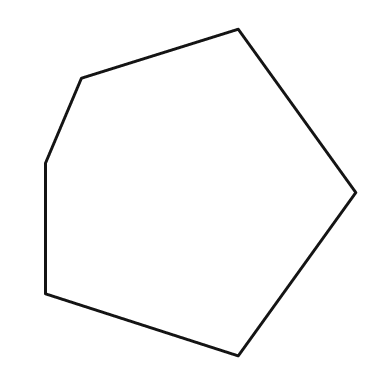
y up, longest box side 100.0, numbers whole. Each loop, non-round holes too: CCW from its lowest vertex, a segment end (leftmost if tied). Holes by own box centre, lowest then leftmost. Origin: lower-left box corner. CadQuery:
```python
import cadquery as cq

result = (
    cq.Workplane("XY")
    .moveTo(59.0, 0.0)
    .lineTo(95.0, 50.0)
    .lineTo(59.0, 100.0)
    .lineTo(11.0, 85.0)
    .lineTo(0.0, 59.0)
    .lineTo(0.0, 19.0)
    .close()
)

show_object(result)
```